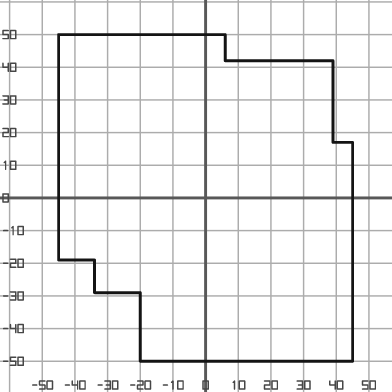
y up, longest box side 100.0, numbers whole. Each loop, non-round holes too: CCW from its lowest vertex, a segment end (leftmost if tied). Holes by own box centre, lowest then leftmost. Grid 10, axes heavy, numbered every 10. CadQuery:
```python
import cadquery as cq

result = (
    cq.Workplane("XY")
    .moveTo(-20.0, -50.0)
    .lineTo(45.0, -50.0)
    .lineTo(45.0, 17.0)
    .lineTo(39.0, 17.0)
    .lineTo(39.0, 42.0)
    .lineTo(6.0, 42.0)
    .lineTo(6.0, 50.0)
    .lineTo(-45.0, 50.0)
    .lineTo(-45.0, -19.0)
    .lineTo(-34.0, -19.0)
    .lineTo(-34.0, -29.0)
    .lineTo(-20.0, -29.0)
    .close()
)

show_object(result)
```